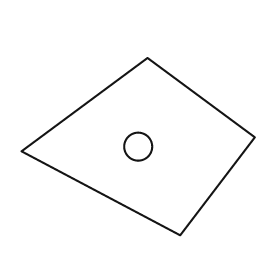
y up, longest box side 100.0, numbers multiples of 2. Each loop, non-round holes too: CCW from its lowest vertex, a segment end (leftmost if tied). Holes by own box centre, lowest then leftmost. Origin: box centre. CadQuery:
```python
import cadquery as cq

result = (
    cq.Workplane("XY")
    .moveTo(18.0, -38.0)
    .lineTo(50.0, 4.0)
    .lineTo(4.0, 38.0)
    .lineTo(-50.0, -2.0)
    .close()
    .moveTo(0.0, 0.0)
    .circle(6.0)
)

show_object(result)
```